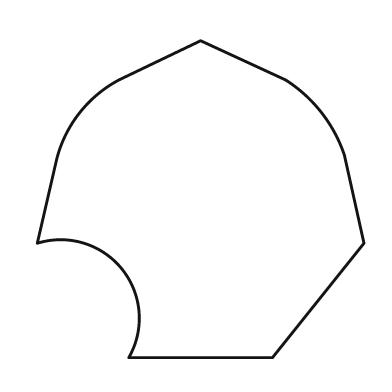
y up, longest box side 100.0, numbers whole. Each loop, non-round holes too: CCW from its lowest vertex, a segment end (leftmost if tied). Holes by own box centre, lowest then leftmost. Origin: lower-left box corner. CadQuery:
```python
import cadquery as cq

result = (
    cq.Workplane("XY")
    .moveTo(28.0, 0.0)
    .lineTo(72.0, 0.0)
    .lineTo(100.0, 35.0)
    .lineTo(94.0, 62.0)
    .threePointArc((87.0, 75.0), (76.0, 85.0))
    .lineTo(50.0, 97.0)
    .lineTo(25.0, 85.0)
    .threePointArc((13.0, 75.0), (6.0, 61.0))
    .lineTo(0.0, 35.0)
    .threePointArc((26.0, 27.0), (28.0, 0.0))
    .close()
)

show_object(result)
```